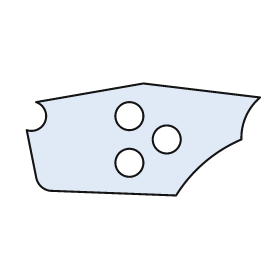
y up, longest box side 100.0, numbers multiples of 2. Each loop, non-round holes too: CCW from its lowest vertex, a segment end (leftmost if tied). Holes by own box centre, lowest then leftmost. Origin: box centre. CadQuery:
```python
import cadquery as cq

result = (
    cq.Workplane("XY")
    .moveTo(14.0, -24.0)
    .threePointArc((26.0, -10.0), (42.0, 0.0))
    .threePointArc((44.0, 10.0), (50.0, 18.0))
    .lineTo(0.0, 24.0)
    .lineTo(-46.0, 16.0)
    .threePointArc((-42.0, 8.0), (-50.0, 4.0))
    .lineTo(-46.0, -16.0)
    .threePointArc((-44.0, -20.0), (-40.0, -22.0))
    .close()
    .moveTo(-6.0, -10.0)
    .circle(6.0)
    .moveTo(10.0, 0.0)
    .circle(6.0)
    .moveTo(-6.0, 10.0)
    .circle(6.0)
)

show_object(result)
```